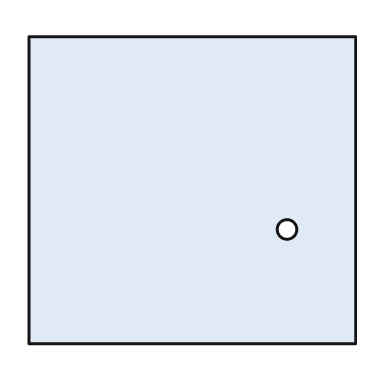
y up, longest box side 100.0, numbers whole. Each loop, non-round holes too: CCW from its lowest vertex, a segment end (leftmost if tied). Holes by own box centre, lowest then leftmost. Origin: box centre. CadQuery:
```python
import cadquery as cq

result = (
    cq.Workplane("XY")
    .moveTo(-50.0, -47.0)
    .lineTo(50.0, -47.0)
    .lineTo(50.0, 47.0)
    .lineTo(-50.0, 47.0)
    .close()
    .moveTo(29.0, -12.0)
    .circle(3.0)
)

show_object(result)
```